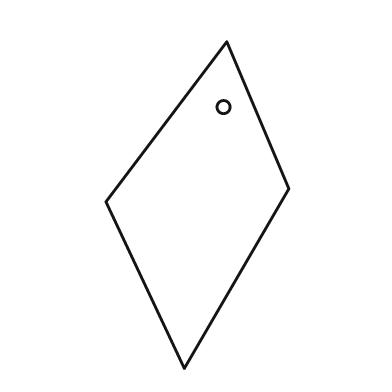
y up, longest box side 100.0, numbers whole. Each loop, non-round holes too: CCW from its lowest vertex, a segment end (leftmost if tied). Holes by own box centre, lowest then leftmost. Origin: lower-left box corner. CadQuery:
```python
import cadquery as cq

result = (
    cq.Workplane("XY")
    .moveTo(24.0, 0.0)
    .lineTo(56.0, 55.0)
    .lineTo(37.0, 100.0)
    .lineTo(0.0, 51.0)
    .close()
    .moveTo(36.0, 80.0)
    .circle(2.0)
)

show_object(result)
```